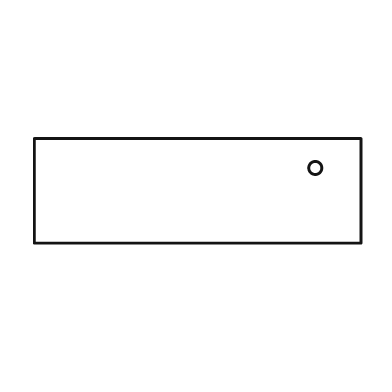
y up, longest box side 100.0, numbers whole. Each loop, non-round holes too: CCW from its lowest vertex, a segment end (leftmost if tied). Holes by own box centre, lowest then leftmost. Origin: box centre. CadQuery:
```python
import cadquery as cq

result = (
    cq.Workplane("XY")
    .moveTo(-50.0, -16.0)
    .lineTo(50.0, -16.0)
    .lineTo(50.0, 16.0)
    .lineTo(-50.0, 16.0)
    .close()
    .moveTo(36.0, 7.0)
    .circle(2.0)
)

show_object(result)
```